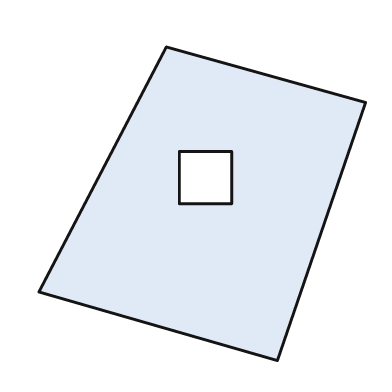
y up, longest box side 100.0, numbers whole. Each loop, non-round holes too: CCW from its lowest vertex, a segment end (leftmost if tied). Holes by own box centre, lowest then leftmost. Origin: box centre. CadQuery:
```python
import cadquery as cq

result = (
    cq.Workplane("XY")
    .moveTo(23.0, -48.0)
    .lineTo(50.0, 31.0)
    .lineTo(-11.0, 48.0)
    .lineTo(-50.0, -27.0)
    .close()
    .moveTo(-7.0, 0.0)
    .lineTo(9.0, 0.0)
    .lineTo(9.0, 16.0)
    .lineTo(-7.0, 16.0)
    .close()
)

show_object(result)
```